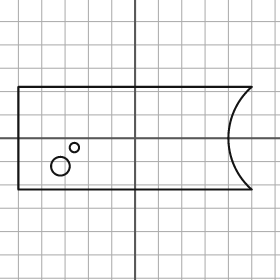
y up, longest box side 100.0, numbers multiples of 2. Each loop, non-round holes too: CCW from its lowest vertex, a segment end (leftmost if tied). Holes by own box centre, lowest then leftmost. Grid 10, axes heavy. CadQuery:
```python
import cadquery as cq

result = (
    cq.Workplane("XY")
    .moveTo(-50.0, -22.0)
    .lineTo(50.0, -22.0)
    .threePointArc((40.0, 0.0), (50.0, 22.0))
    .lineTo(-50.0, 22.0)
    .close()
    .moveTo(-32.0, -12.0)
    .circle(4.0)
    .moveTo(-26.0, -4.0)
    .circle(2.0)
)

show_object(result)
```